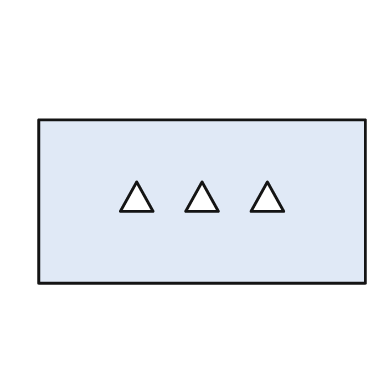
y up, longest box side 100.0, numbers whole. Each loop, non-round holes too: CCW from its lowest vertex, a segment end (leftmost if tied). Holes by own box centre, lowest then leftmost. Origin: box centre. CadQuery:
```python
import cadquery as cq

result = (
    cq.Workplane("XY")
    .moveTo(-50.0, -25.0)
    .lineTo(50.0, -25.0)
    .lineTo(50.0, 25.0)
    .lineTo(-50.0, 25.0)
    .close()
    .moveTo(-25.0, -3.0)
    .lineTo(-15.0, -3.0)
    .lineTo(-20.0, 6.0)
    .close()
    .moveTo(-5.0, -3.0)
    .lineTo(5.0, -3.0)
    .lineTo(0.0, 6.0)
    .close()
    .moveTo(15.0, -3.0)
    .lineTo(25.0, -3.0)
    .lineTo(20.0, 6.0)
    .close()
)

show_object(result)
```